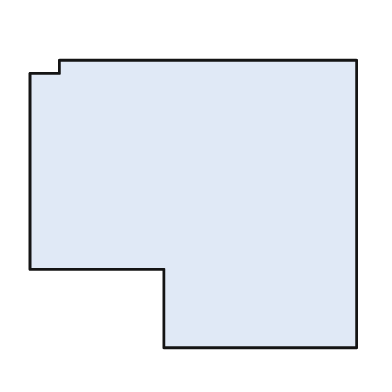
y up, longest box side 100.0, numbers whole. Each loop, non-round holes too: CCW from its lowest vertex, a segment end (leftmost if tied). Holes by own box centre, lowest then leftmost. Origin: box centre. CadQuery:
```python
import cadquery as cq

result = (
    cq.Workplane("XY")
    .moveTo(-9.0, -44.0)
    .lineTo(50.0, -44.0)
    .lineTo(50.0, 44.0)
    .lineTo(-41.0, 44.0)
    .lineTo(-41.0, 40.0)
    .lineTo(-50.0, 40.0)
    .lineTo(-50.0, -20.0)
    .lineTo(-9.0, -20.0)
    .close()
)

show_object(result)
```